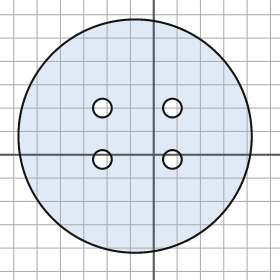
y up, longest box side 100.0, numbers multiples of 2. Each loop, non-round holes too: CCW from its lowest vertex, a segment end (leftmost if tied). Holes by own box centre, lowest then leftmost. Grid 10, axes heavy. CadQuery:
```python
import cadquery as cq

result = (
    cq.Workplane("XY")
    .moveTo(-8.0, 8.0)
    .circle(50.0)
    .moveTo(-22.0, -2.0)
    .circle(4.0)
    .moveTo(8.0, -2.0)
    .circle(4.0)
    .moveTo(-22.0, 20.0)
    .circle(4.0)
    .moveTo(8.0, 20.0)
    .circle(4.0)
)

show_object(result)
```